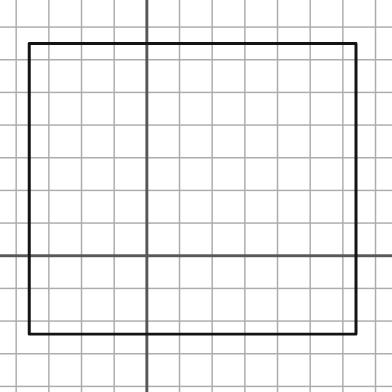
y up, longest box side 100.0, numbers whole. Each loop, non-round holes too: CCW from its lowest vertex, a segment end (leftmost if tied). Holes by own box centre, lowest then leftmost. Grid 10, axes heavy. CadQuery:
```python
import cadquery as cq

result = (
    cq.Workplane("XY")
    .moveTo(-36.0, -24.0)
    .lineTo(64.0, -24.0)
    .lineTo(64.0, 65.0)
    .lineTo(-36.0, 65.0)
    .close()
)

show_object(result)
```